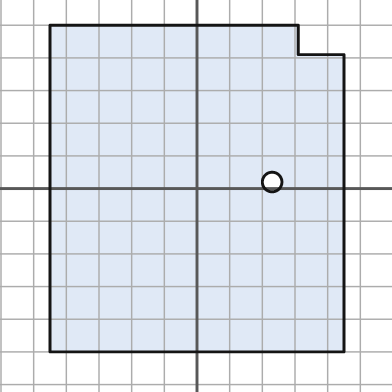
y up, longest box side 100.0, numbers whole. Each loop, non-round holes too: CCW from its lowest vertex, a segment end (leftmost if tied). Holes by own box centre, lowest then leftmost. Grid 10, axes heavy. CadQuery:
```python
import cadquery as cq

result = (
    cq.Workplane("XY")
    .moveTo(-45.0, -50.0)
    .lineTo(45.0, -50.0)
    .lineTo(45.0, 41.0)
    .lineTo(31.0, 41.0)
    .lineTo(31.0, 50.0)
    .lineTo(-45.0, 50.0)
    .close()
    .moveTo(23.0, 2.0)
    .circle(3.0)
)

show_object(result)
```